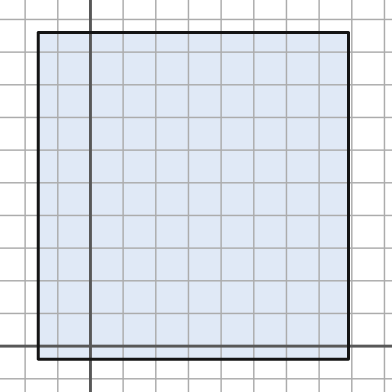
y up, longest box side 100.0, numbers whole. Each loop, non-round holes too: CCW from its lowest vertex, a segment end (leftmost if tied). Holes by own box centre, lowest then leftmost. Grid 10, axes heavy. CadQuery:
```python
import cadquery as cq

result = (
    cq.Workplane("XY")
    .moveTo(-16.0, -4.0)
    .lineTo(79.0, -4.0)
    .lineTo(79.0, 96.0)
    .lineTo(-16.0, 96.0)
    .close()
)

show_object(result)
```